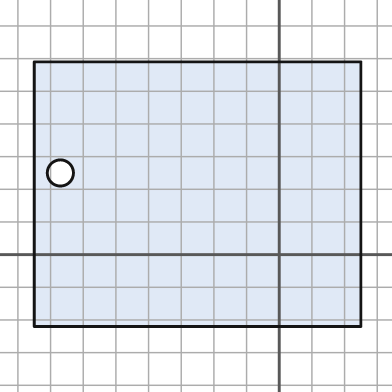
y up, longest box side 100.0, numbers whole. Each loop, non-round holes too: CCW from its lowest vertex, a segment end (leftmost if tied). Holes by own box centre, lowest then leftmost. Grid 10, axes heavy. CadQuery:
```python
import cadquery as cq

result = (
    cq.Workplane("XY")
    .moveTo(-75.0, -22.0)
    .lineTo(25.0, -22.0)
    .lineTo(25.0, 59.0)
    .lineTo(-75.0, 59.0)
    .close()
    .moveTo(-67.0, 25.0)
    .circle(4.0)
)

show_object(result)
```